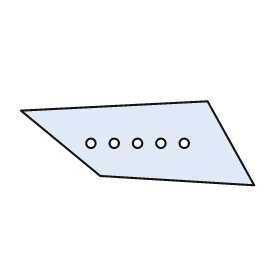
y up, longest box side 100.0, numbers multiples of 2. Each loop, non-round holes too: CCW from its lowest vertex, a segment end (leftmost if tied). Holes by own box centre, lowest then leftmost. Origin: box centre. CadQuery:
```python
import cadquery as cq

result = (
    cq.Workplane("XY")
    .moveTo(50.0, -18.0)
    .lineTo(30.0, 18.0)
    .lineTo(-50.0, 14.0)
    .lineTo(-16.0, -14.0)
    .close()
    .moveTo(-20.0, 0.0)
    .circle(2.0)
    .moveTo(-10.0, 0.0)
    .circle(2.0)
    .moveTo(0.0, 0.0)
    .circle(2.0)
    .moveTo(10.0, 0.0)
    .circle(2.0)
    .moveTo(20.0, 0.0)
    .circle(2.0)
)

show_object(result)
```